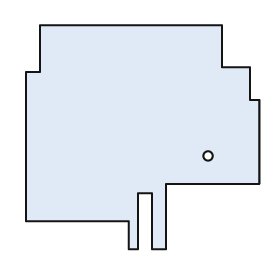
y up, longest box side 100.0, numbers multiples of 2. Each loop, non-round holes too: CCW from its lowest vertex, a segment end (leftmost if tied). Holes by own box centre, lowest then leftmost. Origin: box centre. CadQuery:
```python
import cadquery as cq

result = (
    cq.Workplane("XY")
    .moveTo(-6.0, -48.0)
    .lineTo(-2.0, -48.0)
    .lineTo(-2.0, -24.0)
    .lineTo(4.0, -24.0)
    .lineTo(4.0, -48.0)
    .lineTo(10.0, -48.0)
    .lineTo(10.0, -20.0)
    .lineTo(50.0, -20.0)
    .lineTo(50.0, 16.0)
    .lineTo(46.0, 16.0)
    .lineTo(46.0, 30.0)
    .lineTo(34.0, 30.0)
    .lineTo(34.0, 48.0)
    .lineTo(-44.0, 48.0)
    .lineTo(-44.0, 28.0)
    .lineTo(-50.0, 28.0)
    .lineTo(-50.0, -36.0)
    .lineTo(-6.0, -36.0)
    .close()
    .moveTo(28.0, -8.0)
    .circle(2.0)
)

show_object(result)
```